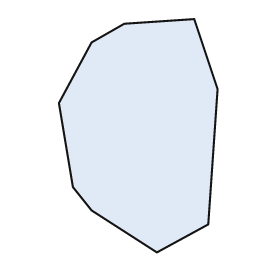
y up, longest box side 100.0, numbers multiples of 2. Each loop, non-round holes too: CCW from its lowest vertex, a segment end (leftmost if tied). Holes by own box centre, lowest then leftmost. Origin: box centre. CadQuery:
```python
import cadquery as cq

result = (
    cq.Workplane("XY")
    .moveTo(8.0, -50.0)
    .lineTo(30.0, -38.0)
    .lineTo(34.0, 20.0)
    .lineTo(24.0, 50.0)
    .lineTo(-6.0, 48.0)
    .lineTo(-20.0, 40.0)
    .lineTo(-34.0, 14.0)
    .lineTo(-28.0, -22.0)
    .lineTo(-20.0, -32.0)
    .close()
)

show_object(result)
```